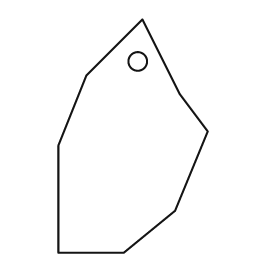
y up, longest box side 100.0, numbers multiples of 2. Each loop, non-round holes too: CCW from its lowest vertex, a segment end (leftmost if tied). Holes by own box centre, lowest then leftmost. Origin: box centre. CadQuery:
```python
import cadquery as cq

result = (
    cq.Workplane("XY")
    .moveTo(-32.0, -50.0)
    .lineTo(-4.0, -50.0)
    .lineTo(18.0, -32.0)
    .lineTo(32.0, 2.0)
    .lineTo(20.0, 18.0)
    .lineTo(4.0, 50.0)
    .lineTo(-20.0, 26.0)
    .lineTo(-32.0, -4.0)
    .close()
    .moveTo(2.0, 32.0)
    .circle(4.0)
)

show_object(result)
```